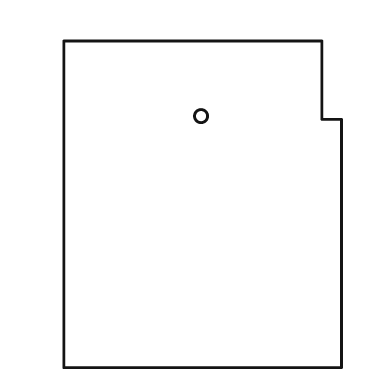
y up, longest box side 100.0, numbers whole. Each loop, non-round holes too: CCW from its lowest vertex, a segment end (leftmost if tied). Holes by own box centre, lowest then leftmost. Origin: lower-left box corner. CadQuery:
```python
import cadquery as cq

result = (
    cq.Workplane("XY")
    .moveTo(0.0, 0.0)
    .lineTo(85.0, 0.0)
    .lineTo(85.0, 76.0)
    .lineTo(79.0, 76.0)
    .lineTo(79.0, 100.0)
    .lineTo(0.0, 100.0)
    .close()
    .moveTo(42.0, 77.0)
    .circle(2.0)
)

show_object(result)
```